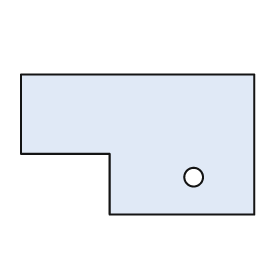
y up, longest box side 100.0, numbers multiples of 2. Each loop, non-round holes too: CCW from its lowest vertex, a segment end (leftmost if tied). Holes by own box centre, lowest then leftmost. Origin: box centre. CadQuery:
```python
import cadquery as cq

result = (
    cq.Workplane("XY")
    .moveTo(-12.0, -30.0)
    .lineTo(50.0, -30.0)
    .lineTo(50.0, 30.0)
    .lineTo(-50.0, 30.0)
    .lineTo(-50.0, -4.0)
    .lineTo(-12.0, -4.0)
    .close()
    .moveTo(24.0, -14.0)
    .circle(4.0)
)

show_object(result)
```